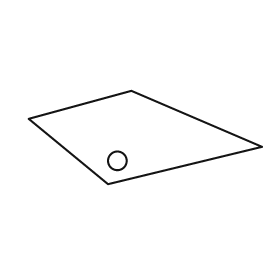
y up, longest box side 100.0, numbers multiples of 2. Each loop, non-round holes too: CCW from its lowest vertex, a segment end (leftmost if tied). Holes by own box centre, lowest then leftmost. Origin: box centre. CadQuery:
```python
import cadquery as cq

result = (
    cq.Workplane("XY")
    .moveTo(-16.0, -20.0)
    .lineTo(50.0, -4.0)
    .lineTo(-6.0, 20.0)
    .lineTo(-50.0, 8.0)
    .close()
    .moveTo(-12.0, -10.0)
    .circle(4.0)
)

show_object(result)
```